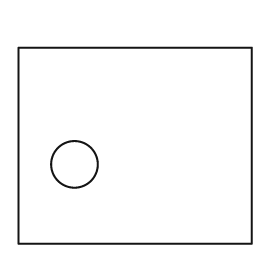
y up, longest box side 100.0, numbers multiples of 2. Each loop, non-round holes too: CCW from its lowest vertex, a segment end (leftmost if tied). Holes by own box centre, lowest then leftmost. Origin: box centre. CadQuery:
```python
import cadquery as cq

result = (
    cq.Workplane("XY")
    .moveTo(-50.0, -42.0)
    .lineTo(50.0, -42.0)
    .lineTo(50.0, 42.0)
    .lineTo(-50.0, 42.0)
    .close()
    .moveTo(-26.0, -8.0)
    .circle(10.0)
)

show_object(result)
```